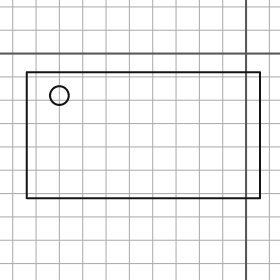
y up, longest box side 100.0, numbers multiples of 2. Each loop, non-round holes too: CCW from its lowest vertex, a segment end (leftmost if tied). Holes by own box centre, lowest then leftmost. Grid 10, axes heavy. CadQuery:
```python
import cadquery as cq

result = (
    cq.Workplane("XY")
    .moveTo(-94.0, -62.0)
    .lineTo(6.0, -62.0)
    .lineTo(6.0, -8.0)
    .lineTo(-94.0, -8.0)
    .close()
    .moveTo(-80.0, -18.0)
    .circle(4.0)
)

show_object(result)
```